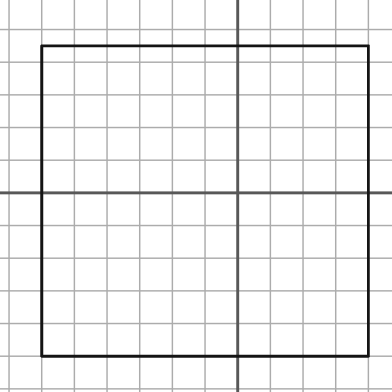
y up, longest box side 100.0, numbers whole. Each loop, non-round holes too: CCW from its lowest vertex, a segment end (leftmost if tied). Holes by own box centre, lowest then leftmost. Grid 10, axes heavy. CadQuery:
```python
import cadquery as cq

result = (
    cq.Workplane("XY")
    .moveTo(-60.0, -50.0)
    .lineTo(40.0, -50.0)
    .lineTo(40.0, 45.0)
    .lineTo(-60.0, 45.0)
    .close()
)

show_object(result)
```